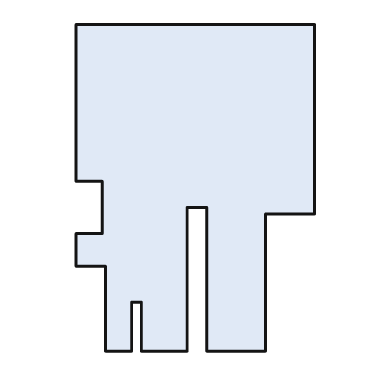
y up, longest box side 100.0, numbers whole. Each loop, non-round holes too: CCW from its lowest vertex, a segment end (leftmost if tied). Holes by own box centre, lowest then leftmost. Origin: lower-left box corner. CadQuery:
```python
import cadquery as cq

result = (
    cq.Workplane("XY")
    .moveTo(9.0, 0.0)
    .lineTo(17.0, 0.0)
    .lineTo(17.0, 15.0)
    .lineTo(20.0, 15.0)
    .lineTo(20.0, 0.0)
    .lineTo(34.0, 0.0)
    .lineTo(34.0, 44.0)
    .lineTo(40.0, 44.0)
    .lineTo(40.0, 0.0)
    .lineTo(58.0, 0.0)
    .lineTo(58.0, 42.0)
    .lineTo(73.0, 42.0)
    .lineTo(73.0, 100.0)
    .lineTo(0.0, 100.0)
    .lineTo(0.0, 52.0)
    .lineTo(8.0, 52.0)
    .lineTo(8.0, 36.0)
    .lineTo(0.0, 36.0)
    .lineTo(0.0, 26.0)
    .lineTo(9.0, 26.0)
    .close()
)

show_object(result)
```